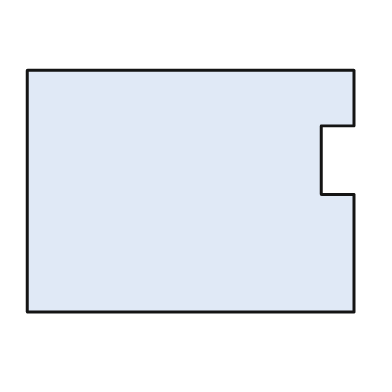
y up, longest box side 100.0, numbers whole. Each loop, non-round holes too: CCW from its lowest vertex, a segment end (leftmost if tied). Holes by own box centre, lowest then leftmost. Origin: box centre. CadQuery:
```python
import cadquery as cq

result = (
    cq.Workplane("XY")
    .moveTo(-50.0, -37.0)
    .lineTo(50.0, -37.0)
    .lineTo(50.0, -1.0)
    .lineTo(40.0, -1.0)
    .lineTo(40.0, 20.0)
    .lineTo(50.0, 20.0)
    .lineTo(50.0, 37.0)
    .lineTo(-50.0, 37.0)
    .close()
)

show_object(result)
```